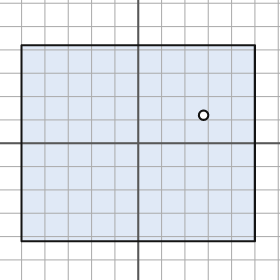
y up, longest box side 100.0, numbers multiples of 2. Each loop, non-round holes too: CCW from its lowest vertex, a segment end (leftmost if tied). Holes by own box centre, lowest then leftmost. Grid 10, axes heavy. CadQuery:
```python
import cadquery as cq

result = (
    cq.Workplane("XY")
    .moveTo(-50.0, -42.0)
    .lineTo(50.0, -42.0)
    .lineTo(50.0, 42.0)
    .lineTo(-50.0, 42.0)
    .close()
    .moveTo(28.0, 12.0)
    .circle(2.0)
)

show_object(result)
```